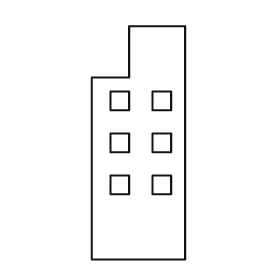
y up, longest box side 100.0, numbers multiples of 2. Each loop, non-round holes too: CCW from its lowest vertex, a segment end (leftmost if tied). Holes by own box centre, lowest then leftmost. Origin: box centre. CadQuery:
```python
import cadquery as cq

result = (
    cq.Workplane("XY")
    .moveTo(-20.0, -50.0)
    .lineTo(20.0, -50.0)
    .lineTo(20.0, 50.0)
    .lineTo(-4.0, 50.0)
    .lineTo(-4.0, 28.0)
    .lineTo(-20.0, 28.0)
    .close()
    .moveTo(-12.0, -22.0)
    .lineTo(-4.0, -22.0)
    .lineTo(-4.0, -14.0)
    .lineTo(-12.0, -14.0)
    .close()
    .moveTo(6.0, -22.0)
    .lineTo(14.0, -22.0)
    .lineTo(14.0, -14.0)
    .lineTo(6.0, -14.0)
    .close()
    .moveTo(-12.0, -4.0)
    .lineTo(-4.0, -4.0)
    .lineTo(-4.0, 4.0)
    .lineTo(-12.0, 4.0)
    .close()
    .moveTo(6.0, -4.0)
    .lineTo(14.0, -4.0)
    .lineTo(14.0, 4.0)
    .lineTo(6.0, 4.0)
    .close()
    .moveTo(-12.0, 14.0)
    .lineTo(-4.0, 14.0)
    .lineTo(-4.0, 22.0)
    .lineTo(-12.0, 22.0)
    .close()
    .moveTo(6.0, 14.0)
    .lineTo(14.0, 14.0)
    .lineTo(14.0, 22.0)
    .lineTo(6.0, 22.0)
    .close()
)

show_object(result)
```